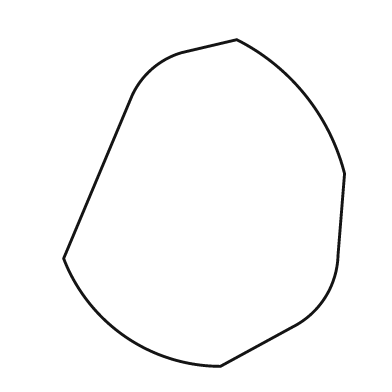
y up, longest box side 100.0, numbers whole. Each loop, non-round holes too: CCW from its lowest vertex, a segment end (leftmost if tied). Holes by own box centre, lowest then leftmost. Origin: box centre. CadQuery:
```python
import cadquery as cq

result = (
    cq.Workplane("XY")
    .moveTo(5.0, -50.0)
    .lineTo(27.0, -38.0)
    .threePointArc((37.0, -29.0), (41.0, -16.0))
    .lineTo(43.0, 9.0)
    .threePointArc((31.0, 33.0), (10.0, 50.0))
    .lineTo(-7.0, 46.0)
    .threePointArc((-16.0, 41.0), (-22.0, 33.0))
    .lineTo(-43.0, -17.0)
    .threePointArc((-24.0, -41.0), (5.0, -50.0))
    .close()
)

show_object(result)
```